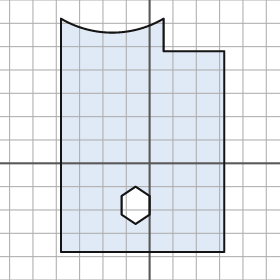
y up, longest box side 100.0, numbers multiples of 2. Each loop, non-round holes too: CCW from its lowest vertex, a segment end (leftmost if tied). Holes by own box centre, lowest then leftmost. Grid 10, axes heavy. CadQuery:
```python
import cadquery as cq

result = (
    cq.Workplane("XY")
    .moveTo(-38.0, -38.0)
    .lineTo(32.0, -38.0)
    .lineTo(32.0, 48.0)
    .lineTo(6.0, 48.0)
    .lineTo(6.0, 62.0)
    .threePointArc((-16.0, 56.0), (-38.0, 62.0))
    .close()
    .moveTo(-6.0, -26.0)
    .lineTo(0.0, -22.0)
    .lineTo(0.0, -14.0)
    .lineTo(-6.0, -10.0)
    .lineTo(-12.0, -14.0)
    .lineTo(-12.0, -22.0)
    .close()
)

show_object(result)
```